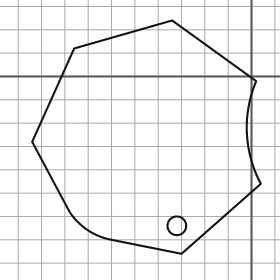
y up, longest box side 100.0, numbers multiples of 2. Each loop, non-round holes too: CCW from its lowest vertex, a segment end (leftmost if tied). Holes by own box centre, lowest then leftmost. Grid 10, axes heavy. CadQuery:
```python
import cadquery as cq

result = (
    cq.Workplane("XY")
    .moveTo(-30.0, -76.0)
    .lineTo(4.0, -46.0)
    .threePointArc((-2.0, -24.0), (2.0, -2.0))
    .lineTo(-34.0, 24.0)
    .lineTo(-76.0, 12.0)
    .lineTo(-94.0, -28.0)
    .lineTo(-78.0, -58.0)
    .threePointArc((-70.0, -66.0), (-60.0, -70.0))
    .close()
    .moveTo(-32.0, -64.0)
    .circle(4.0)
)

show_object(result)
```